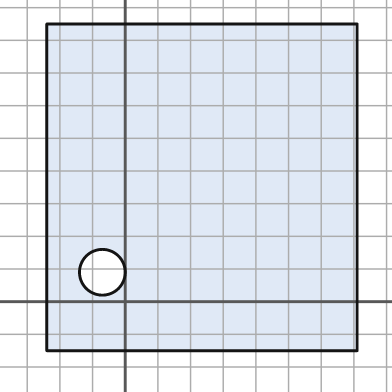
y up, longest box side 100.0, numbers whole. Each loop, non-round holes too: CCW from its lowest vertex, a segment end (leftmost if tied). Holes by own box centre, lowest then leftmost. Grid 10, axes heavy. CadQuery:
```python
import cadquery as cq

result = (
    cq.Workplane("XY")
    .moveTo(-24.0, -15.0)
    .lineTo(71.0, -15.0)
    .lineTo(71.0, 85.0)
    .lineTo(-24.0, 85.0)
    .close()
    .moveTo(-7.0, 9.0)
    .circle(7.0)
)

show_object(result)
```